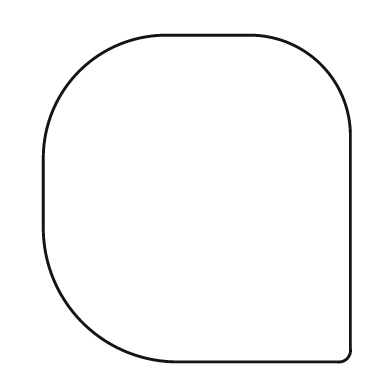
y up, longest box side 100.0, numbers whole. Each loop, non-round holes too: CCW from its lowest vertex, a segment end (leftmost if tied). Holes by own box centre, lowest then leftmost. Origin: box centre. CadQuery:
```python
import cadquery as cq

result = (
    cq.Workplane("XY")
    .moveTo(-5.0, -50.0)
    .lineTo(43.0, -50.0)
    .threePointArc((46.0, -49.0), (47.0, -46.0))
    .lineTo(47.0, 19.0)
    .threePointArc((38.0, 41.0), (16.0, 50.0))
    .lineTo(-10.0, 50.0)
    .threePointArc((-36.0, 39.0), (-47.0, 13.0))
    .lineTo(-47.0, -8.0)
    .threePointArc((-35.0, -38.0), (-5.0, -50.0))
    .close()
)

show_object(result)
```